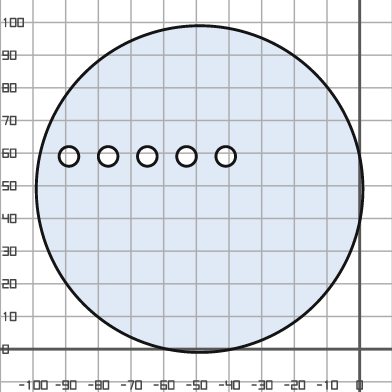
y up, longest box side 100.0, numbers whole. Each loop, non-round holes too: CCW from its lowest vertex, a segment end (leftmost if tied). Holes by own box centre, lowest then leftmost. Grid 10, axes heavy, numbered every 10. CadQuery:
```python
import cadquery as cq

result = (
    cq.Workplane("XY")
    .moveTo(-49.0, 49.0)
    .circle(50.0)
    .moveTo(-89.0, 59.0)
    .circle(3.0)
    .moveTo(-77.0, 59.0)
    .circle(3.0)
    .moveTo(-65.0, 59.0)
    .circle(3.0)
    .moveTo(-53.0, 59.0)
    .circle(3.0)
    .moveTo(-41.0, 59.0)
    .circle(3.0)
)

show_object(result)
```